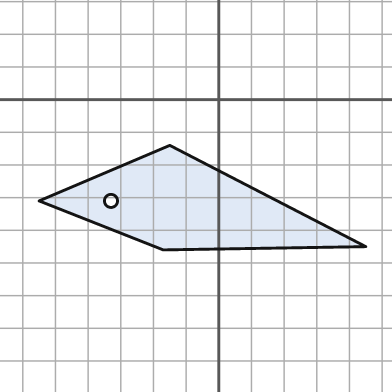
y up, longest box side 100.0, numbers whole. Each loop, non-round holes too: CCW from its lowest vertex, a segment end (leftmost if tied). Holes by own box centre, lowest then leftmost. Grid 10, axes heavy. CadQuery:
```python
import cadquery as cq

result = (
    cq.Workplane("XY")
    .moveTo(-17.0, -46.0)
    .lineTo(45.0, -45.0)
    .lineTo(-15.0, -14.0)
    .lineTo(-55.0, -31.0)
    .close()
    .moveTo(-33.0, -31.0)
    .circle(2.0)
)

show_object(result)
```